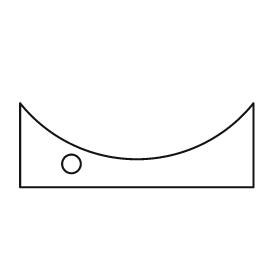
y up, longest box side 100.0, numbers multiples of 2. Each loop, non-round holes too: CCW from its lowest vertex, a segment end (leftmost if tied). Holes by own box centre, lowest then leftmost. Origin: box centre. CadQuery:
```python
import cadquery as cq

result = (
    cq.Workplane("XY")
    .moveTo(-50.0, -18.0)
    .lineTo(50.0, -18.0)
    .lineTo(50.0, 18.0)
    .threePointArc((0.0, -6.0), (-50.0, 18.0))
    .close()
    .moveTo(-28.0, -8.0)
    .circle(4.0)
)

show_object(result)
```